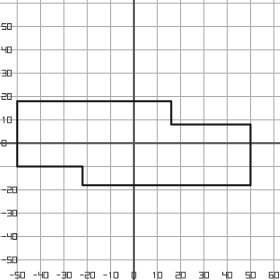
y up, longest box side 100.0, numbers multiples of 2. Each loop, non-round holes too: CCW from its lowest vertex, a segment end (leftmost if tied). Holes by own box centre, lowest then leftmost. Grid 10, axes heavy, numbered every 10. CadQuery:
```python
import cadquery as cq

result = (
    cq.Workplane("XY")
    .moveTo(-22.0, -18.0)
    .lineTo(50.0, -18.0)
    .lineTo(50.0, 8.0)
    .lineTo(16.0, 8.0)
    .lineTo(16.0, 18.0)
    .lineTo(-50.0, 18.0)
    .lineTo(-50.0, -10.0)
    .lineTo(-22.0, -10.0)
    .close()
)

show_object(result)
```